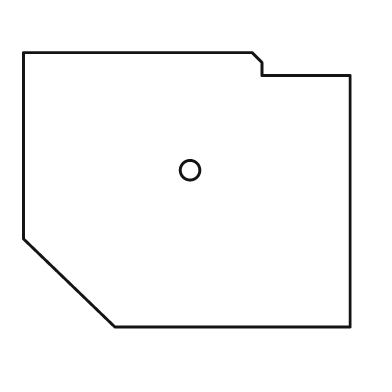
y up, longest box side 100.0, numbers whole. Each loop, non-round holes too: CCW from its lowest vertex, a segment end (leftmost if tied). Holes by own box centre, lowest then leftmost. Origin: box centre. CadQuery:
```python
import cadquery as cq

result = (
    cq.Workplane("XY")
    .moveTo(-22.0, -42.0)
    .lineTo(50.0, -42.0)
    .lineTo(50.0, 35.0)
    .lineTo(23.0, 35.0)
    .lineTo(23.0, 39.0)
    .lineTo(20.0, 42.0)
    .lineTo(-50.0, 42.0)
    .lineTo(-50.0, -15.0)
    .close()
    .moveTo(1.0, 6.0)
    .circle(3.0)
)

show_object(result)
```